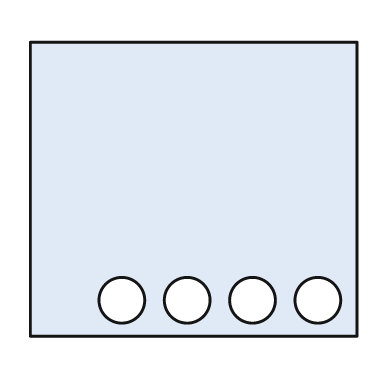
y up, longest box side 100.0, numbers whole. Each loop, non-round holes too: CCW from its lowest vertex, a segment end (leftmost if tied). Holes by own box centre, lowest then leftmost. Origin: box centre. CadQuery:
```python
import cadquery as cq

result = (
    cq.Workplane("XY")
    .moveTo(-50.0, -45.0)
    .lineTo(50.0, -45.0)
    .lineTo(50.0, 45.0)
    .lineTo(-50.0, 45.0)
    .close()
    .moveTo(-22.0, -34.0)
    .circle(7.0)
    .moveTo(-2.0, -34.0)
    .circle(7.0)
    .moveTo(18.0, -34.0)
    .circle(7.0)
    .moveTo(38.0, -34.0)
    .circle(7.0)
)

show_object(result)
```